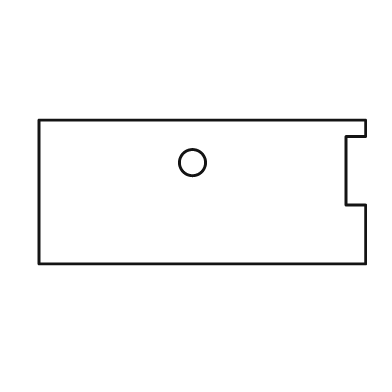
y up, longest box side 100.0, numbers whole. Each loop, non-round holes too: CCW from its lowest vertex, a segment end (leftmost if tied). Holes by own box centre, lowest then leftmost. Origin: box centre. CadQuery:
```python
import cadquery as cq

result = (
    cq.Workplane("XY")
    .moveTo(-50.0, -22.0)
    .lineTo(50.0, -22.0)
    .lineTo(50.0, -4.0)
    .lineTo(44.0, -4.0)
    .lineTo(44.0, 17.0)
    .lineTo(50.0, 17.0)
    .lineTo(50.0, 22.0)
    .lineTo(-50.0, 22.0)
    .close()
    .moveTo(-3.0, 9.0)
    .circle(4.0)
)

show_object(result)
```